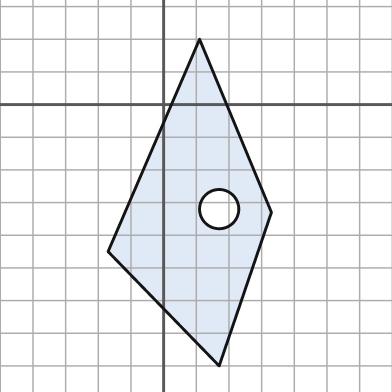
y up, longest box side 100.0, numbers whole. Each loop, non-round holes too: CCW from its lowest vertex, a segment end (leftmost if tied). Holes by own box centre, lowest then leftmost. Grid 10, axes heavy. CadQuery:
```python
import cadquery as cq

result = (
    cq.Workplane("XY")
    .moveTo(17.0, -80.0)
    .lineTo(33.0, -33.0)
    .lineTo(11.0, 20.0)
    .lineTo(-17.0, -45.0)
    .close()
    .moveTo(17.0, -32.0)
    .circle(6.0)
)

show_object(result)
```